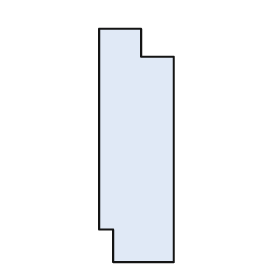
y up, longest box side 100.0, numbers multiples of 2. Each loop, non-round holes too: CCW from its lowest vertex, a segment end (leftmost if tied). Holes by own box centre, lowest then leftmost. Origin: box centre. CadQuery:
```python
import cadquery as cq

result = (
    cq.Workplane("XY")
    .moveTo(-10.0, -50.0)
    .lineTo(16.0, -50.0)
    .lineTo(16.0, 38.0)
    .lineTo(2.0, 38.0)
    .lineTo(2.0, 50.0)
    .lineTo(-16.0, 50.0)
    .lineTo(-16.0, -36.0)
    .lineTo(-10.0, -36.0)
    .close()
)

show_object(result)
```